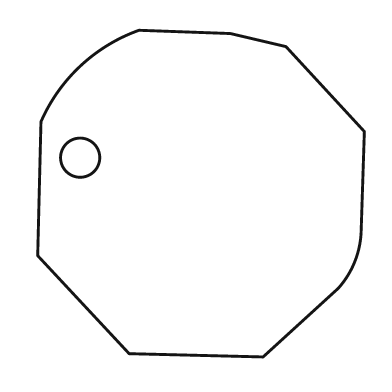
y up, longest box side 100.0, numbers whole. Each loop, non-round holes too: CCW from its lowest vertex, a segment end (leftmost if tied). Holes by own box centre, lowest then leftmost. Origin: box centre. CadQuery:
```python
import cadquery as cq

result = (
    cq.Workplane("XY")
    .moveTo(19.0, -50.0)
    .lineTo(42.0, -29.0)
    .threePointArc((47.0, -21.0), (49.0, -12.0))
    .lineTo(50.0, 19.0)
    .lineTo(26.0, 45.0)
    .lineTo(9.0, 49.0)
    .lineTo(-19.0, 50.0)
    .threePointArc((-37.0, 39.0), (-49.0, 22.0))
    .lineTo(-50.0, -19.0)
    .lineTo(-22.0, -49.0)
    .close()
    .moveTo(-37.0, 11.0)
    .circle(6.0)
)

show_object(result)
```